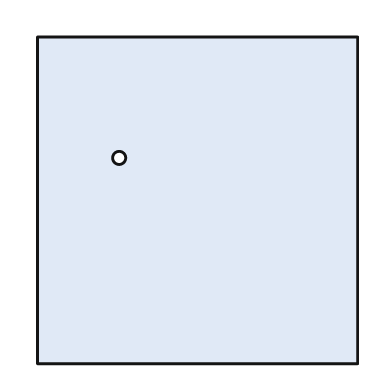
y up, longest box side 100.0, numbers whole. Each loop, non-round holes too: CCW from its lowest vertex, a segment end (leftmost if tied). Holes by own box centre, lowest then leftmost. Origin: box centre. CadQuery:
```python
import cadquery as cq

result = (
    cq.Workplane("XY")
    .moveTo(-49.0, -50.0)
    .lineTo(49.0, -50.0)
    .lineTo(49.0, 50.0)
    .lineTo(-49.0, 50.0)
    .close()
    .moveTo(-24.0, 13.0)
    .circle(2.0)
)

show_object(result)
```